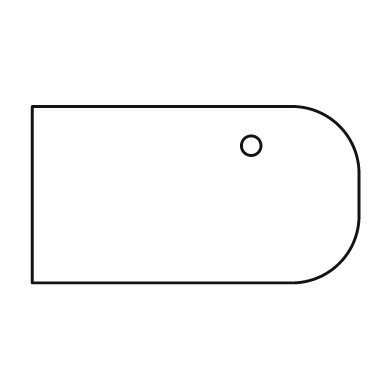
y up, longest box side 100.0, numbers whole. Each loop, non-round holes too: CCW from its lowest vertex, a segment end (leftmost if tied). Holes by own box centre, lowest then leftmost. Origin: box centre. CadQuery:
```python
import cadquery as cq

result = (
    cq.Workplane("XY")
    .moveTo(-50.0, -27.0)
    .lineTo(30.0, -27.0)
    .threePointArc((44.0, -21.0), (50.0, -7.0))
    .lineTo(50.0, 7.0)
    .threePointArc((44.0, 21.0), (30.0, 27.0))
    .lineTo(-50.0, 27.0)
    .close()
    .moveTo(17.0, 15.0)
    .circle(3.0)
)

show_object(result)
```